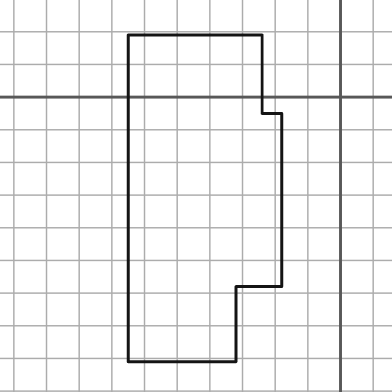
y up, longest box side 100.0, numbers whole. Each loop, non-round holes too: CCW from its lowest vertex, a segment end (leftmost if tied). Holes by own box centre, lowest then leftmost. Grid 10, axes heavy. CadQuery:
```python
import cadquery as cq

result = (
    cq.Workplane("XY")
    .moveTo(-65.0, -81.0)
    .lineTo(-32.0, -81.0)
    .lineTo(-32.0, -58.0)
    .lineTo(-18.0, -58.0)
    .lineTo(-18.0, -5.0)
    .lineTo(-24.0, -5.0)
    .lineTo(-24.0, 19.0)
    .lineTo(-65.0, 19.0)
    .close()
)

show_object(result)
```